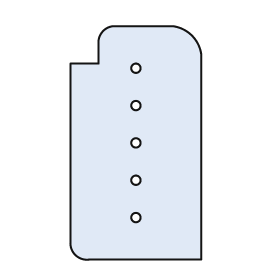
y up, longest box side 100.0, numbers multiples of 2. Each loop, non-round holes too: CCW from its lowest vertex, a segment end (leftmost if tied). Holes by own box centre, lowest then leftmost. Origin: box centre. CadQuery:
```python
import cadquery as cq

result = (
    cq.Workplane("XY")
    .moveTo(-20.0, -50.0)
    .lineTo(28.0, -50.0)
    .lineTo(28.0, 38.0)
    .threePointArc((24.0, 46.0), (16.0, 50.0))
    .lineTo(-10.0, 50.0)
    .threePointArc((-14.0, 48.0), (-16.0, 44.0))
    .lineTo(-16.0, 34.0)
    .lineTo(-28.0, 34.0)
    .lineTo(-28.0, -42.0)
    .threePointArc((-26.0, -48.0), (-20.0, -50.0))
    .close()
    .moveTo(0.0, -32.0)
    .circle(2.0)
    .moveTo(0.0, -16.0)
    .circle(2.0)
    .moveTo(0.0, 0.0)
    .circle(2.0)
    .moveTo(0.0, 16.0)
    .circle(2.0)
    .moveTo(0.0, 32.0)
    .circle(2.0)
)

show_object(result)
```